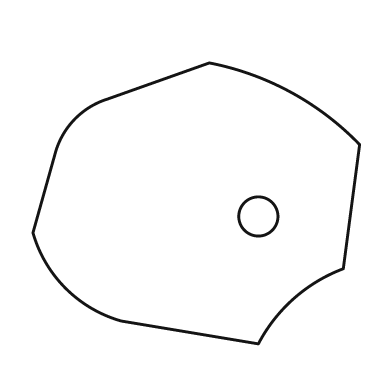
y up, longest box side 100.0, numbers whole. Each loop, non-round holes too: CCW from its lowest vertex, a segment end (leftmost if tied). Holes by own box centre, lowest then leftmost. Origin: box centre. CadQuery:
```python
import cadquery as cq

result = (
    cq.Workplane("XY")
    .moveTo(19.0, -43.0)
    .threePointArc((30.0, -29.0), (45.0, -20.0))
    .lineTo(50.0, 18.0)
    .threePointArc((29.0, 34.0), (4.0, 43.0))
    .lineTo(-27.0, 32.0)
    .threePointArc((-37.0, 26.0), (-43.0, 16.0))
    .lineTo(-50.0, -9.0)
    .threePointArc((-40.0, -26.0), (-23.0, -36.0))
    .close()
    .moveTo(19.0, -4.0)
    .circle(6.0)
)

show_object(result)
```